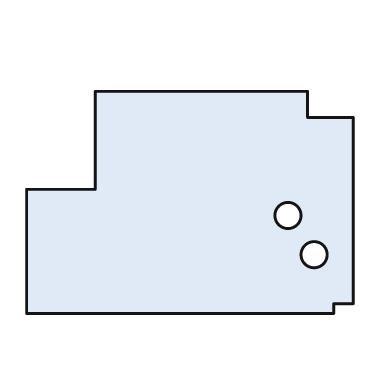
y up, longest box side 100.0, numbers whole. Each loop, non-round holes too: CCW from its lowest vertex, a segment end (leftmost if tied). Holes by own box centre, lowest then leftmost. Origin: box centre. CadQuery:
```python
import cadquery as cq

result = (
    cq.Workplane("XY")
    .moveTo(-50.0, -34.0)
    .lineTo(44.0, -34.0)
    .lineTo(44.0, -31.0)
    .lineTo(50.0, -31.0)
    .lineTo(50.0, 26.0)
    .lineTo(36.0, 26.0)
    .lineTo(36.0, 34.0)
    .lineTo(-29.0, 34.0)
    .lineTo(-29.0, 4.0)
    .lineTo(-50.0, 4.0)
    .close()
    .moveTo(38.0, -16.0)
    .circle(4.0)
    .moveTo(30.0, -4.0)
    .circle(4.0)
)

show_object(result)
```